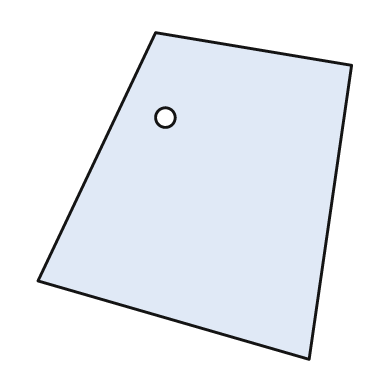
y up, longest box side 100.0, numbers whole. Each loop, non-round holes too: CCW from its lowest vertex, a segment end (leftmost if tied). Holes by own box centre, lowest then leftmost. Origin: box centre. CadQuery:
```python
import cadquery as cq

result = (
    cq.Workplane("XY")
    .moveTo(35.0, -50.0)
    .lineTo(48.0, 40.0)
    .lineTo(-12.0, 50.0)
    .lineTo(-48.0, -26.0)
    .close()
    .moveTo(-9.0, 24.0)
    .circle(3.0)
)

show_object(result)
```